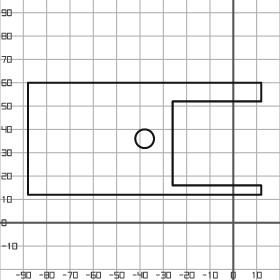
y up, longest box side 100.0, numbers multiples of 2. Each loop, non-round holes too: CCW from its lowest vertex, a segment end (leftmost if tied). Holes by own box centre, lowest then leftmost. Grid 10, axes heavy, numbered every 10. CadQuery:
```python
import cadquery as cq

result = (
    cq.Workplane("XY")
    .moveTo(-88.0, 12.0)
    .lineTo(12.0, 12.0)
    .lineTo(12.0, 16.0)
    .lineTo(-26.0, 16.0)
    .lineTo(-26.0, 52.0)
    .lineTo(12.0, 52.0)
    .lineTo(12.0, 60.0)
    .lineTo(-88.0, 60.0)
    .close()
    .moveTo(-38.0, 36.0)
    .circle(4.0)
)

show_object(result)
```